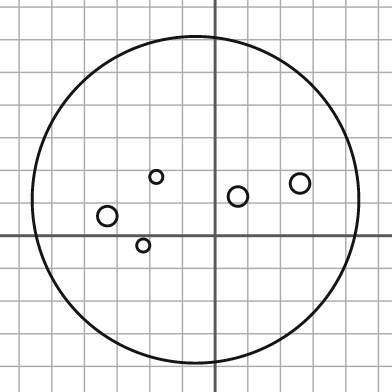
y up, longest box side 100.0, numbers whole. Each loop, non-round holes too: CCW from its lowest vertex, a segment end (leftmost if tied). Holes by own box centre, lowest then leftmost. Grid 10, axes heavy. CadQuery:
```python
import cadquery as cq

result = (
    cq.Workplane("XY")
    .moveTo(-6.0, 11.0)
    .circle(50.0)
    .moveTo(-22.0, -3.0)
    .circle(2.0)
    .moveTo(-33.0, 6.0)
    .circle(3.0)
    .moveTo(7.0, 12.0)
    .circle(3.0)
    .moveTo(26.0, 16.0)
    .circle(3.0)
    .moveTo(-18.0, 18.0)
    .circle(2.0)
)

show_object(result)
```